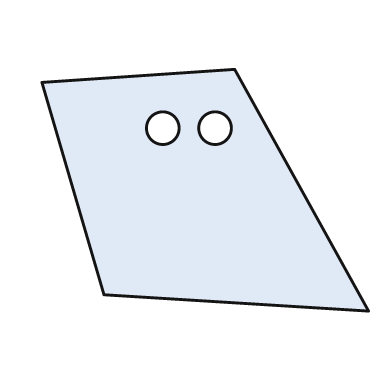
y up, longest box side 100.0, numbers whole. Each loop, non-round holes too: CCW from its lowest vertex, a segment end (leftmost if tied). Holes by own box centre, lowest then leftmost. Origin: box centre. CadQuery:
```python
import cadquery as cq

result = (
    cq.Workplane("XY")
    .moveTo(50.0, -37.0)
    .lineTo(9.0, 37.0)
    .lineTo(-50.0, 33.0)
    .lineTo(-31.0, -32.0)
    .close()
    .moveTo(-13.0, 19.0)
    .circle(5.0)
    .moveTo(3.0, 19.0)
    .circle(5.0)
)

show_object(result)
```